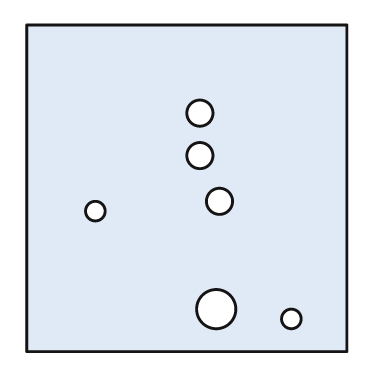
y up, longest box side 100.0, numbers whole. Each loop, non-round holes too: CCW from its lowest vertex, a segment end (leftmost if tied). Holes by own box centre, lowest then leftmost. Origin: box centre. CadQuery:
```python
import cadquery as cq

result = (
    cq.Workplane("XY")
    .moveTo(-49.0, -50.0)
    .lineTo(49.0, -50.0)
    .lineTo(49.0, 50.0)
    .lineTo(-49.0, 50.0)
    .close()
    .moveTo(32.0, -40.0)
    .circle(3.0)
    .moveTo(9.0, -37.0)
    .circle(6.0)
    .moveTo(-28.0, -7.0)
    .circle(3.0)
    .moveTo(10.0, -4.0)
    .circle(4.0)
    .moveTo(4.0, 10.0)
    .circle(4.0)
    .moveTo(4.0, 23.0)
    .circle(4.0)
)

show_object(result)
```